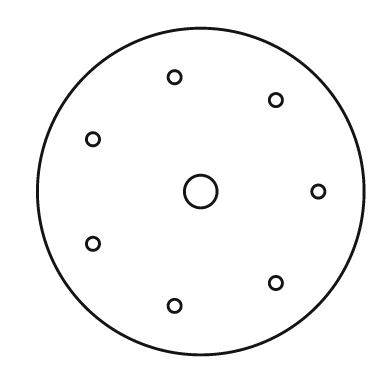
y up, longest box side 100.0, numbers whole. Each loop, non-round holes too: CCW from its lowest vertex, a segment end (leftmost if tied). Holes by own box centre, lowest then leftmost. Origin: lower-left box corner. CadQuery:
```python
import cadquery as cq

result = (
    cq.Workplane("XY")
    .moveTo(50.0, 50.0)
    .circle(50.0)
    .moveTo(42.0, 15.0)
    .circle(2.0)
    .moveTo(73.0, 22.0)
    .circle(2.0)
    .moveTo(17.0, 34.0)
    .circle(2.0)
    .moveTo(50.0, 50.0)
    .circle(5.0)
    .moveTo(86.0, 50.0)
    .circle(2.0)
    .moveTo(17.0, 66.0)
    .circle(2.0)
    .moveTo(73.0, 78.0)
    .circle(2.0)
    .moveTo(42.0, 85.0)
    .circle(2.0)
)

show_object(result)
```